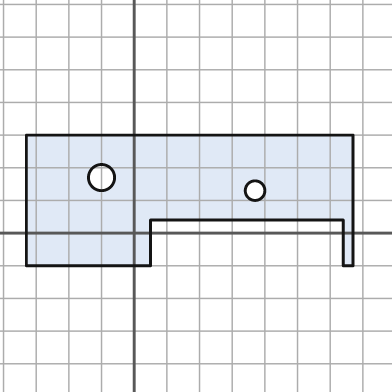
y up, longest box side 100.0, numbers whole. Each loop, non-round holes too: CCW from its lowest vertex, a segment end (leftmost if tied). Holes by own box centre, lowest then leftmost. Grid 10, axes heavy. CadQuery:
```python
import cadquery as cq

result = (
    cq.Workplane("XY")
    .moveTo(-33.0, -10.0)
    .lineTo(5.0, -10.0)
    .lineTo(5.0, 4.0)
    .lineTo(64.0, 4.0)
    .lineTo(64.0, -10.0)
    .lineTo(67.0, -10.0)
    .lineTo(67.0, 30.0)
    .lineTo(-33.0, 30.0)
    .close()
    .moveTo(37.0, 13.0)
    .circle(3.0)
    .moveTo(-10.0, 17.0)
    .circle(4.0)
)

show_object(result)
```